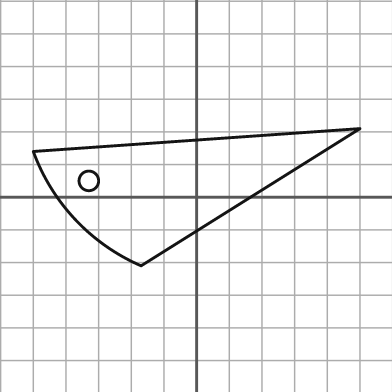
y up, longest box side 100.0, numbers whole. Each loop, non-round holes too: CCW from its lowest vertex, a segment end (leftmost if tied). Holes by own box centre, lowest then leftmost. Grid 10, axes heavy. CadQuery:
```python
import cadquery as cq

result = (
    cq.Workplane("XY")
    .moveTo(-17.0, -21.0)
    .lineTo(50.0, 21.0)
    .lineTo(-50.0, 14.0)
    .threePointArc((-37.0, -7.0), (-17.0, -21.0))
    .close()
    .moveTo(-33.0, 5.0)
    .circle(3.0)
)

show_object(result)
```